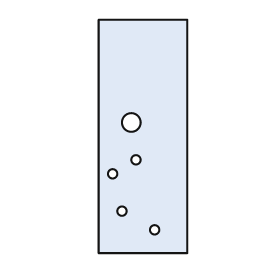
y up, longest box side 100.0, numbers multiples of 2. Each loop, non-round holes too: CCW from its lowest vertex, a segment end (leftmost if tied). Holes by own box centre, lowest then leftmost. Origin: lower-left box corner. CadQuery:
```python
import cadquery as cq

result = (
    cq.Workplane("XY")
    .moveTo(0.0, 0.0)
    .lineTo(38.0, 0.0)
    .lineTo(38.0, 100.0)
    .lineTo(0.0, 100.0)
    .close()
    .moveTo(24.0, 10.0)
    .circle(2.0)
    .moveTo(10.0, 18.0)
    .circle(2.0)
    .moveTo(6.0, 34.0)
    .circle(2.0)
    .moveTo(16.0, 40.0)
    .circle(2.0)
    .moveTo(14.0, 56.0)
    .circle(4.0)
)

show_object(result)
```